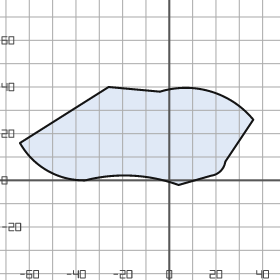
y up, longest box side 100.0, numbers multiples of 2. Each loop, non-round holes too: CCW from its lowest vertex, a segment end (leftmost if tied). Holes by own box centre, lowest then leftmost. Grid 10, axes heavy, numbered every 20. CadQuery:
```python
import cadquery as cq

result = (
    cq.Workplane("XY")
    .moveTo(4.0, -2.0)
    .lineTo(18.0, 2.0)
    .threePointArc((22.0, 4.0), (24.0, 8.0))
    .lineTo(36.0, 26.0)
    .threePointArc((18.0, 38.0), (-4.0, 38.0))
    .lineTo(-26.0, 40.0)
    .lineTo(-64.0, 16.0)
    .threePointArc((-52.0, 4.0), (-36.0, 0.0))
    .threePointArc((-16.0, 2.0), (4.0, -2.0))
    .close()
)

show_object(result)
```